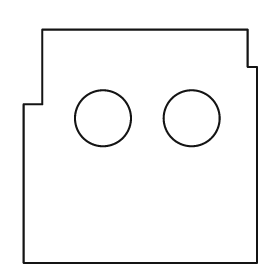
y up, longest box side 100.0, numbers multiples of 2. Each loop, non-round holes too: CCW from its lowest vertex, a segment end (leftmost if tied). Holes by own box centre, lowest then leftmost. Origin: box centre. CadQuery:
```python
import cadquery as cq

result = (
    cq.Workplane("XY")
    .moveTo(-50.0, -50.0)
    .lineTo(50.0, -50.0)
    .lineTo(50.0, 34.0)
    .lineTo(46.0, 34.0)
    .lineTo(46.0, 50.0)
    .lineTo(-42.0, 50.0)
    .lineTo(-42.0, 18.0)
    .lineTo(-50.0, 18.0)
    .close()
    .moveTo(-16.0, 12.0)
    .circle(12.0)
    .moveTo(22.0, 12.0)
    .circle(12.0)
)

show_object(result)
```